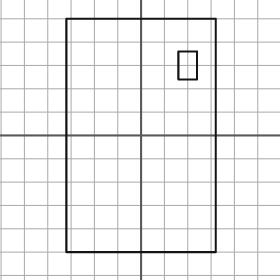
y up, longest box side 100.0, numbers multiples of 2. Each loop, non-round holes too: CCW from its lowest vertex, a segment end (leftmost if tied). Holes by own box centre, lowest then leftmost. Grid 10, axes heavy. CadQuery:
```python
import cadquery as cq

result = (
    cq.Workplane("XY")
    .moveTo(-32.0, -50.0)
    .lineTo(32.0, -50.0)
    .lineTo(32.0, 50.0)
    .lineTo(-32.0, 50.0)
    .close()
    .moveTo(16.0, 24.0)
    .lineTo(24.0, 24.0)
    .lineTo(24.0, 36.0)
    .lineTo(16.0, 36.0)
    .close()
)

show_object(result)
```